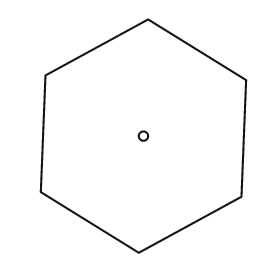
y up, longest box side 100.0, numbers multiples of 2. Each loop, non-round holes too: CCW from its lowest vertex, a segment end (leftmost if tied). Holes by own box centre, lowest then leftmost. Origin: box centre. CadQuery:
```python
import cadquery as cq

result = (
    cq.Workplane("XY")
    .moveTo(-2.0, -50.0)
    .lineTo(42.0, -26.0)
    .lineTo(44.0, 24.0)
    .lineTo(2.0, 50.0)
    .lineTo(-42.0, 26.0)
    .lineTo(-44.0, -24.0)
    .close()
    .moveTo(0.0, 0.0)
    .circle(2.0)
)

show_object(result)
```